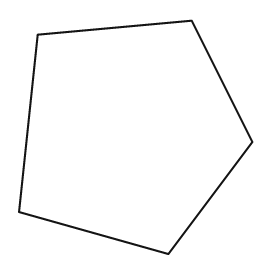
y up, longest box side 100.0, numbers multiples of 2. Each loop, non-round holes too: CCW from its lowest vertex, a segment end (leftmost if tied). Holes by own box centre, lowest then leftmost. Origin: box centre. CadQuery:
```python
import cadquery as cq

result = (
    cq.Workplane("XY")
    .moveTo(14.0, -50.0)
    .lineTo(50.0, -2.0)
    .lineTo(24.0, 50.0)
    .lineTo(-42.0, 44.0)
    .lineTo(-50.0, -32.0)
    .close()
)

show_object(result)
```